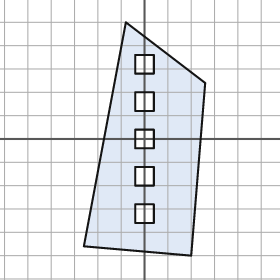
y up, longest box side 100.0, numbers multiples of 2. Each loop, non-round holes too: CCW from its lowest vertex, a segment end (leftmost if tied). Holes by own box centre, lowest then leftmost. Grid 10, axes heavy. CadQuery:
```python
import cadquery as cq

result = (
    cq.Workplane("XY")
    .moveTo(20.0, -50.0)
    .lineTo(26.0, 24.0)
    .lineTo(-8.0, 50.0)
    .lineTo(-26.0, -46.0)
    .close()
    .moveTo(-4.0, -36.0)
    .lineTo(4.0, -36.0)
    .lineTo(4.0, -28.0)
    .lineTo(-4.0, -28.0)
    .close()
    .moveTo(-4.0, -20.0)
    .lineTo(4.0, -20.0)
    .lineTo(4.0, -12.0)
    .lineTo(-4.0, -12.0)
    .close()
    .moveTo(-4.0, -4.0)
    .lineTo(4.0, -4.0)
    .lineTo(4.0, 4.0)
    .lineTo(-4.0, 4.0)
    .close()
    .moveTo(-4.0, 12.0)
    .lineTo(4.0, 12.0)
    .lineTo(4.0, 20.0)
    .lineTo(-4.0, 20.0)
    .close()
    .moveTo(-4.0, 28.0)
    .lineTo(4.0, 28.0)
    .lineTo(4.0, 36.0)
    .lineTo(-4.0, 36.0)
    .close()
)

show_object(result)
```